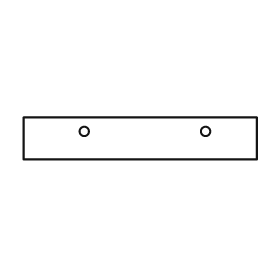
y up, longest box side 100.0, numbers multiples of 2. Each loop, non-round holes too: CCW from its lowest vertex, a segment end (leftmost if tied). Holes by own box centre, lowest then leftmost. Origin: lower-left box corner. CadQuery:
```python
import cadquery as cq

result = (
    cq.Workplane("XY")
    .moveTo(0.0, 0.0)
    .lineTo(100.0, 0.0)
    .lineTo(100.0, 18.0)
    .lineTo(0.0, 18.0)
    .close()
    .moveTo(26.0, 12.0)
    .circle(2.0)
    .moveTo(78.0, 12.0)
    .circle(2.0)
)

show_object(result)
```